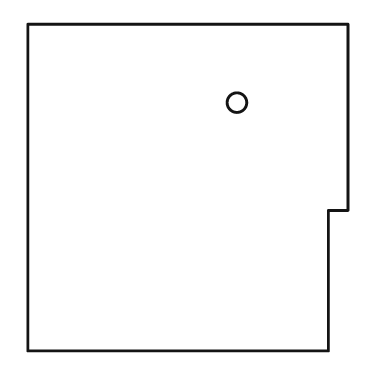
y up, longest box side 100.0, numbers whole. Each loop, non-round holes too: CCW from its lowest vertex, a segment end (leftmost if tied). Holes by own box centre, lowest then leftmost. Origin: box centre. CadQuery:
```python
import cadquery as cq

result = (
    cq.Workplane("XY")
    .moveTo(-49.0, -50.0)
    .lineTo(43.0, -50.0)
    .lineTo(43.0, -7.0)
    .lineTo(49.0, -7.0)
    .lineTo(49.0, 50.0)
    .lineTo(-49.0, 50.0)
    .close()
    .moveTo(15.0, 26.0)
    .circle(3.0)
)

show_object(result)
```